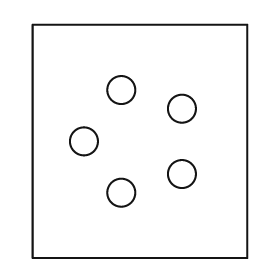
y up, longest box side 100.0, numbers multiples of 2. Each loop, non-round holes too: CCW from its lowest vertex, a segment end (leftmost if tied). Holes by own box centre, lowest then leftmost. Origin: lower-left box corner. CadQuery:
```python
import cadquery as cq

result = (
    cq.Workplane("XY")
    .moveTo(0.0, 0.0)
    .lineTo(92.0, 0.0)
    .lineTo(92.0, 100.0)
    .lineTo(0.0, 100.0)
    .close()
    .moveTo(38.0, 28.0)
    .circle(6.0)
    .moveTo(64.0, 36.0)
    .circle(6.0)
    .moveTo(22.0, 50.0)
    .circle(6.0)
    .moveTo(64.0, 64.0)
    .circle(6.0)
    .moveTo(38.0, 72.0)
    .circle(6.0)
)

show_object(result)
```